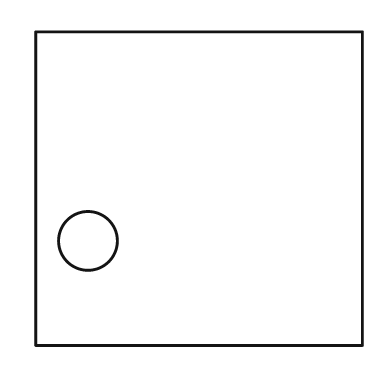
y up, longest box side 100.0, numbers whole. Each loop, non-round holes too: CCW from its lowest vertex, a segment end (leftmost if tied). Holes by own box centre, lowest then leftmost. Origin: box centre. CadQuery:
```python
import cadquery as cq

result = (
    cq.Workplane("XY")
    .moveTo(-50.0, -48.0)
    .lineTo(50.0, -48.0)
    .lineTo(50.0, 48.0)
    .lineTo(-50.0, 48.0)
    .close()
    .moveTo(-34.0, -16.0)
    .circle(9.0)
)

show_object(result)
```